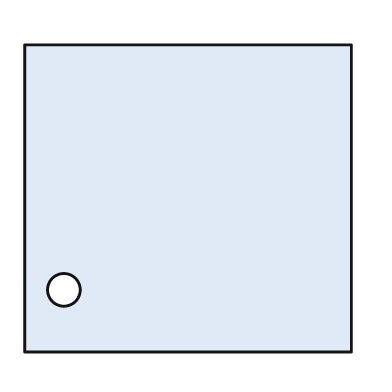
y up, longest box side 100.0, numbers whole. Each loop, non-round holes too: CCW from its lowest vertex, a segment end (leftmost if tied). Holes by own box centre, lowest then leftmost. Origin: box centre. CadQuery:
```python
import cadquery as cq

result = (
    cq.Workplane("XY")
    .moveTo(-50.0, -47.0)
    .lineTo(50.0, -47.0)
    .lineTo(50.0, 47.0)
    .lineTo(-50.0, 47.0)
    .close()
    .moveTo(-38.0, -28.0)
    .circle(5.0)
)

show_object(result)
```